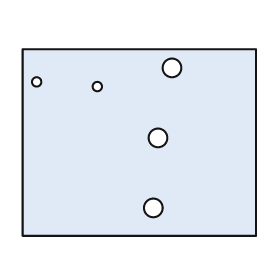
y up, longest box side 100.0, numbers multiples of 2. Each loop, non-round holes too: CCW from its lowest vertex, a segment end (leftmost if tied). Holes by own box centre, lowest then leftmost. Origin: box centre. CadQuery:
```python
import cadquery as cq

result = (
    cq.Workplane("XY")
    .moveTo(-50.0, -40.0)
    .lineTo(50.0, -40.0)
    .lineTo(50.0, 40.0)
    .lineTo(-50.0, 40.0)
    .close()
    .moveTo(6.0, -28.0)
    .circle(4.0)
    .moveTo(8.0, 2.0)
    .circle(4.0)
    .moveTo(-18.0, 24.0)
    .circle(2.0)
    .moveTo(-44.0, 26.0)
    .circle(2.0)
    .moveTo(14.0, 32.0)
    .circle(4.0)
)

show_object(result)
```